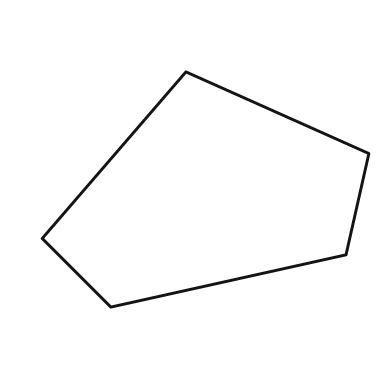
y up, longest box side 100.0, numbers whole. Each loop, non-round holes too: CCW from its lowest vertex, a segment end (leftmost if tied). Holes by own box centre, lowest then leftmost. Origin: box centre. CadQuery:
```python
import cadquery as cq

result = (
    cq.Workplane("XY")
    .moveTo(-29.0, -36.0)
    .lineTo(43.0, -20.0)
    .lineTo(50.0, 11.0)
    .lineTo(-6.0, 36.0)
    .lineTo(-50.0, -15.0)
    .close()
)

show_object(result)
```